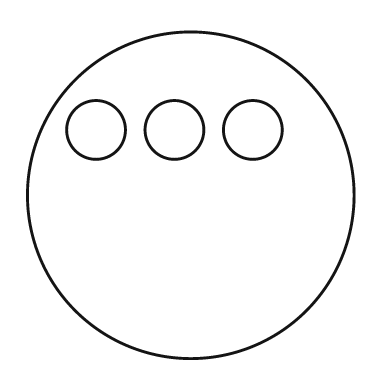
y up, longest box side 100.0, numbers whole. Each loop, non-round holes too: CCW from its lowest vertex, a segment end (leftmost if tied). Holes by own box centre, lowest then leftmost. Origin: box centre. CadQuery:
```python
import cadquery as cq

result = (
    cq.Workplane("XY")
    .moveTo(0.0, 0.0)
    .circle(50.0)
    .moveTo(-29.0, 20.0)
    .circle(9.0)
    .moveTo(-5.0, 20.0)
    .circle(9.0)
    .moveTo(19.0, 20.0)
    .circle(9.0)
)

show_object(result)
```